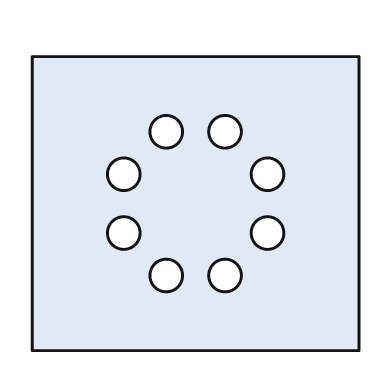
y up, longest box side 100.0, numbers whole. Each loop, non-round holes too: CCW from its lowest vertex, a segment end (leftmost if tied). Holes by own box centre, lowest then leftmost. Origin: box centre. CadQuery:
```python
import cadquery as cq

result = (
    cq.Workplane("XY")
    .moveTo(-50.0, -45.0)
    .lineTo(50.0, -45.0)
    .lineTo(50.0, 45.0)
    .lineTo(-50.0, 45.0)
    .close()
    .moveTo(-9.0, -22.0)
    .circle(5.0)
    .moveTo(9.0, -22.0)
    .circle(5.0)
    .moveTo(-22.0, -9.0)
    .circle(5.0)
    .moveTo(22.0, -9.0)
    .circle(5.0)
    .moveTo(-22.0, 9.0)
    .circle(5.0)
    .moveTo(22.0, 9.0)
    .circle(5.0)
    .moveTo(-9.0, 22.0)
    .circle(5.0)
    .moveTo(9.0, 22.0)
    .circle(5.0)
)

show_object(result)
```